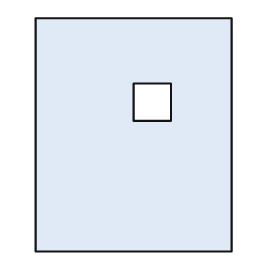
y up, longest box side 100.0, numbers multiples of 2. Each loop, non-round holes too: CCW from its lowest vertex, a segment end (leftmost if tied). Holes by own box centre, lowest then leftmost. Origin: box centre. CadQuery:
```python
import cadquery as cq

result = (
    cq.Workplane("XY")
    .moveTo(-42.0, -50.0)
    .lineTo(42.0, -50.0)
    .lineTo(42.0, 50.0)
    .lineTo(-42.0, 50.0)
    .close()
    .moveTo(0.0, 6.0)
    .lineTo(16.0, 6.0)
    .lineTo(16.0, 22.0)
    .lineTo(0.0, 22.0)
    .close()
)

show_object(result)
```